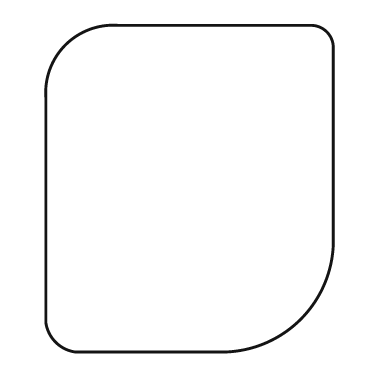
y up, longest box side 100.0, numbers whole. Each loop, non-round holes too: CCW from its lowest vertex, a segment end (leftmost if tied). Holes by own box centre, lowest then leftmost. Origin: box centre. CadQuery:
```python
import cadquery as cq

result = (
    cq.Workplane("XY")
    .moveTo(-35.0, -50.0)
    .lineTo(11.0, -50.0)
    .threePointArc((34.0, -40.0), (44.0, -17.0))
    .lineTo(44.0, 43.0)
    .threePointArc((42.0, 48.0), (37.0, 50.0))
    .lineTo(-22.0, 50.0)
    .threePointArc((-38.0, 44.0), (-44.0, 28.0))
    .lineTo(-44.0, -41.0)
    .threePointArc((-41.0, -47.0), (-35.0, -50.0))
    .close()
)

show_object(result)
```